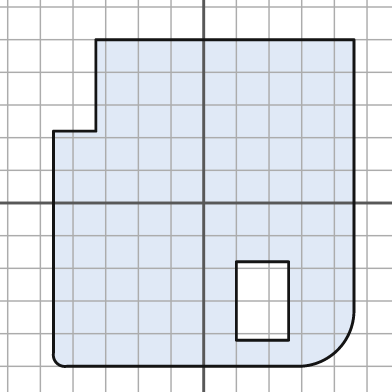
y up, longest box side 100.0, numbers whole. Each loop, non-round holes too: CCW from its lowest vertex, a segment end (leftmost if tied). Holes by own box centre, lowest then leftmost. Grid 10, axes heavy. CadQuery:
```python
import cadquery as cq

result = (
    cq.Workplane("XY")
    .moveTo(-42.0, -50.0)
    .lineTo(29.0, -50.0)
    .threePointArc((41.0, -45.0), (46.0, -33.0))
    .lineTo(46.0, 50.0)
    .lineTo(-33.0, 50.0)
    .lineTo(-33.0, 22.0)
    .lineTo(-46.0, 22.0)
    .lineTo(-46.0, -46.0)
    .threePointArc((-45.0, -49.0), (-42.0, -50.0))
    .close()
    .moveTo(10.0, -42.0)
    .lineTo(26.0, -42.0)
    .lineTo(26.0, -18.0)
    .lineTo(10.0, -18.0)
    .close()
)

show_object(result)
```